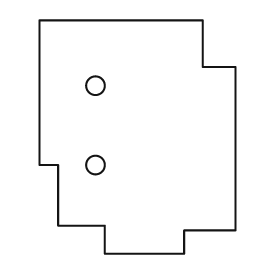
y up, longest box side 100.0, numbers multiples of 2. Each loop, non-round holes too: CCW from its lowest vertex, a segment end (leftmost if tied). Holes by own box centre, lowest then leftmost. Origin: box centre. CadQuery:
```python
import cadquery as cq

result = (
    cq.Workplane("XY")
    .moveTo(-14.0, -50.0)
    .lineTo(20.0, -50.0)
    .lineTo(20.0, -40.0)
    .lineTo(42.0, -40.0)
    .lineTo(42.0, 30.0)
    .lineTo(28.0, 30.0)
    .lineTo(28.0, 50.0)
    .lineTo(-42.0, 50.0)
    .lineTo(-42.0, -12.0)
    .lineTo(-34.0, -12.0)
    .lineTo(-34.0, -38.0)
    .lineTo(-14.0, -38.0)
    .close()
    .moveTo(-18.0, -12.0)
    .circle(4.0)
    .moveTo(-18.0, 22.0)
    .circle(4.0)
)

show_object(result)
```